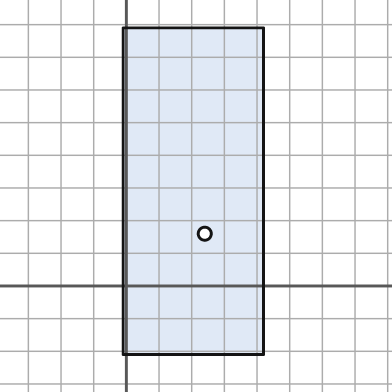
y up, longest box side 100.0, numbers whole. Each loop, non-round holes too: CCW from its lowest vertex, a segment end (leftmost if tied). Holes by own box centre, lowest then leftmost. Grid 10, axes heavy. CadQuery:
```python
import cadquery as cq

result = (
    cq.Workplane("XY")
    .moveTo(-1.0, -21.0)
    .lineTo(42.0, -21.0)
    .lineTo(42.0, 79.0)
    .lineTo(-1.0, 79.0)
    .close()
    .moveTo(24.0, 16.0)
    .circle(2.0)
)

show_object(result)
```